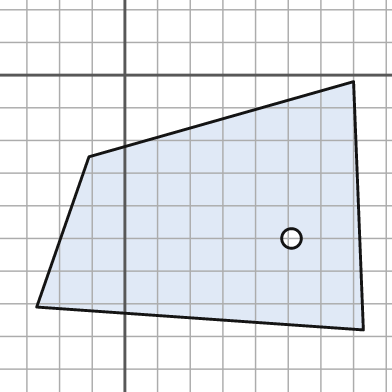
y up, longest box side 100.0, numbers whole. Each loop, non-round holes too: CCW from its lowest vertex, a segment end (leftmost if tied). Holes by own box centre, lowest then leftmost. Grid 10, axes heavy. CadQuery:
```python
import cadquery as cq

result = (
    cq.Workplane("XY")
    .moveTo(73.0, -78.0)
    .lineTo(70.0, -2.0)
    .lineTo(-11.0, -25.0)
    .lineTo(-27.0, -71.0)
    .close()
    .moveTo(51.0, -50.0)
    .circle(3.0)
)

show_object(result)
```